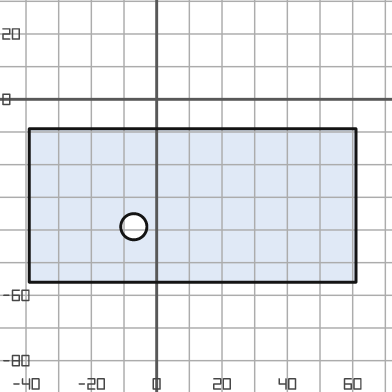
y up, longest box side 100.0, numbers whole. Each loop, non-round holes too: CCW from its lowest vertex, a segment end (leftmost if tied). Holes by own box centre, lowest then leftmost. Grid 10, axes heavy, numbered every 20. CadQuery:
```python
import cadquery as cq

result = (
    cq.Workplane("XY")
    .moveTo(-39.0, -56.0)
    .lineTo(61.0, -56.0)
    .lineTo(61.0, -9.0)
    .lineTo(-39.0, -9.0)
    .close()
    .moveTo(-7.0, -39.0)
    .circle(4.0)
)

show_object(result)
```